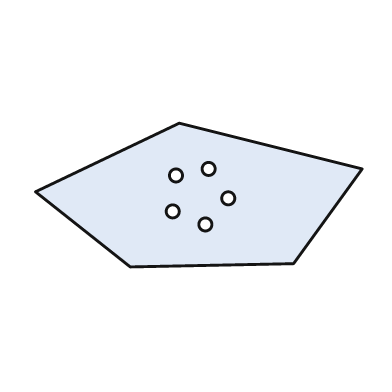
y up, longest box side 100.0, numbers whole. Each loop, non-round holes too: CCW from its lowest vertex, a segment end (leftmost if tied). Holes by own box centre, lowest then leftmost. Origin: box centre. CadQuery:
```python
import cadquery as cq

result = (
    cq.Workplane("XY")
    .moveTo(-21.0, -22.0)
    .lineTo(29.0, -21.0)
    .lineTo(50.0, 8.0)
    .lineTo(-6.0, 22.0)
    .lineTo(-50.0, 1.0)
    .close()
    .moveTo(2.0, -9.0)
    .circle(2.0)
    .moveTo(-8.0, -5.0)
    .circle(2.0)
    .moveTo(9.0, -1.0)
    .circle(2.0)
    .moveTo(-7.0, 6.0)
    .circle(2.0)
    .moveTo(3.0, 8.0)
    .circle(2.0)
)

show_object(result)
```